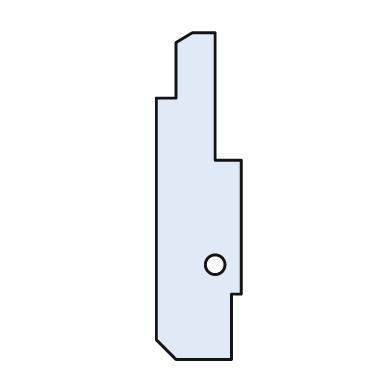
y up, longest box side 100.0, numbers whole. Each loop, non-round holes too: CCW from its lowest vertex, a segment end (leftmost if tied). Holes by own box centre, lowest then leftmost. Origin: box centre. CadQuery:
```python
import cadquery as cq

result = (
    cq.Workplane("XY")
    .moveTo(-7.0, -50.0)
    .lineTo(10.0, -50.0)
    .lineTo(10.0, -30.0)
    .lineTo(13.0, -30.0)
    .lineTo(13.0, 11.0)
    .lineTo(5.0, 11.0)
    .lineTo(5.0, 50.0)
    .lineTo(-2.0, 50.0)
    .lineTo(-7.0, 47.0)
    .lineTo(-7.0, 30.0)
    .lineTo(-13.0, 30.0)
    .lineTo(-13.0, -44.0)
    .close()
    .moveTo(5.0, -21.0)
    .circle(3.0)
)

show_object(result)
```